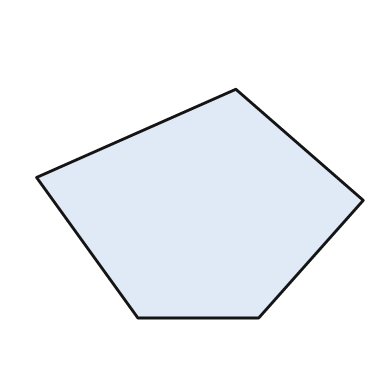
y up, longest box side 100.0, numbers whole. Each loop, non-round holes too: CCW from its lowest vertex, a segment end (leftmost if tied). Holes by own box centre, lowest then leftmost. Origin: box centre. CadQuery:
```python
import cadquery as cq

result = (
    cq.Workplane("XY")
    .moveTo(-19.0, -35.0)
    .lineTo(18.0, -35.0)
    .lineTo(50.0, 1.0)
    .lineTo(11.0, 35.0)
    .lineTo(-50.0, 8.0)
    .close()
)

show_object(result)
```